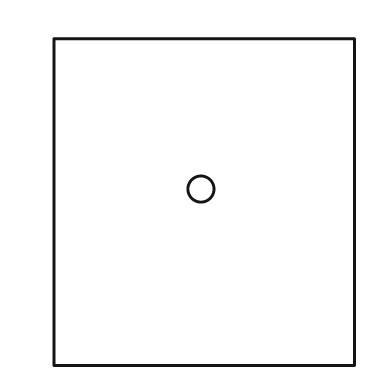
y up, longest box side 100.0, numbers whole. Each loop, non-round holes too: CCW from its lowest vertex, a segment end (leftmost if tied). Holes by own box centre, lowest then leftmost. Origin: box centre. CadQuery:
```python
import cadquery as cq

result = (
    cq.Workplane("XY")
    .moveTo(-46.0, -50.0)
    .lineTo(46.0, -50.0)
    .lineTo(46.0, 50.0)
    .lineTo(-46.0, 50.0)
    .close()
    .moveTo(-1.0, 4.0)
    .circle(4.0)
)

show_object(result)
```